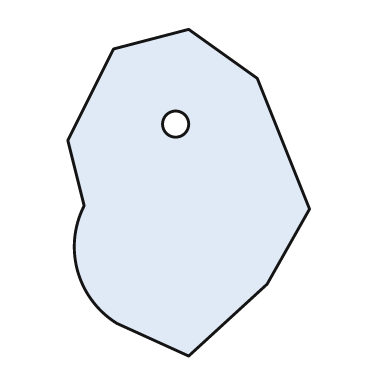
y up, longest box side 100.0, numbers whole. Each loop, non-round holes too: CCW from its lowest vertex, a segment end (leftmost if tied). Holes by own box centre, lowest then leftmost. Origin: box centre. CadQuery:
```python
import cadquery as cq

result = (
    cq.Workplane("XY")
    .moveTo(0.0, -50.0)
    .lineTo(24.0, -28.0)
    .lineTo(37.0, -5.0)
    .lineTo(21.0, 35.0)
    .lineTo(0.0, 50.0)
    .lineTo(-23.0, 44.0)
    .lineTo(-37.0, 16.0)
    .lineTo(-32.0, -4.0)
    .threePointArc((-34.0, -24.0), (-22.0, -40.0))
    .close()
    .moveTo(-4.0, 21.0)
    .circle(4.0)
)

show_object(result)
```